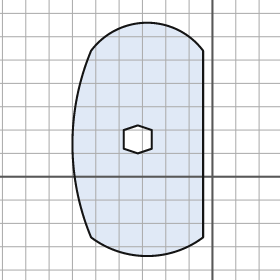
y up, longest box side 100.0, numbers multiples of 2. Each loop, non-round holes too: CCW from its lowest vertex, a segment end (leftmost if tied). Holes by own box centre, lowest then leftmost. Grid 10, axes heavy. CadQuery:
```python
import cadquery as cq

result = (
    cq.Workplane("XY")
    .moveTo(-52.0, -26.0)
    .threePointArc((-28.0, -34.0), (-4.0, -26.0))
    .lineTo(-4.0, 54.0)
    .threePointArc((-28.0, 66.0), (-52.0, 54.0))
    .threePointArc((-60.0, 14.0), (-52.0, -26.0))
    .close()
    .moveTo(-32.0, 10.0)
    .lineTo(-26.0, 12.0)
    .lineTo(-26.0, 20.0)
    .lineTo(-32.0, 22.0)
    .lineTo(-38.0, 20.0)
    .lineTo(-38.0, 12.0)
    .close()
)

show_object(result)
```